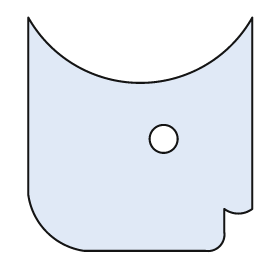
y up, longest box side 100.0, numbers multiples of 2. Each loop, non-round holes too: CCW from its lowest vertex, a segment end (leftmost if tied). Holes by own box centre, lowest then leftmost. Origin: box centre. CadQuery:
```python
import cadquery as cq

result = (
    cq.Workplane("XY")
    .moveTo(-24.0, -50.0)
    .lineTo(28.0, -50.0)
    .threePointArc((34.0, -48.0), (36.0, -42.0))
    .lineTo(36.0, -32.0)
    .threePointArc((42.0, -34.0), (48.0, -32.0))
    .lineTo(48.0, 50.0)
    .threePointArc((0.0, 22.0), (-48.0, 50.0))
    .lineTo(-48.0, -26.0)
    .threePointArc((-40.0, -42.0), (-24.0, -50.0))
    .close()
    .moveTo(10.0, -2.0)
    .circle(6.0)
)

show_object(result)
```